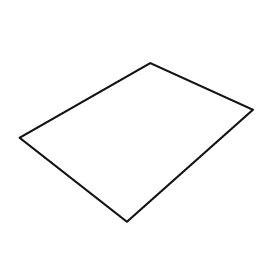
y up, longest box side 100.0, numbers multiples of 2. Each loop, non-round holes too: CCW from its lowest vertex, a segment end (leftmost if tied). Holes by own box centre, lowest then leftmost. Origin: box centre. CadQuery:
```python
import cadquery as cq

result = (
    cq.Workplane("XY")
    .moveTo(-4.0, -34.0)
    .lineTo(50.0, 14.0)
    .lineTo(6.0, 34.0)
    .lineTo(-50.0, 2.0)
    .close()
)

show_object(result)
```